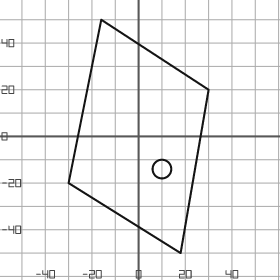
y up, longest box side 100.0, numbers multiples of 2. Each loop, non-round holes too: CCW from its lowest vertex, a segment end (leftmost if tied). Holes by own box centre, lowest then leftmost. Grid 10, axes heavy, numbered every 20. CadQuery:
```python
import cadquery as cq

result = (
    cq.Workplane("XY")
    .moveTo(18.0, -50.0)
    .lineTo(30.0, 20.0)
    .lineTo(-16.0, 50.0)
    .lineTo(-30.0, -20.0)
    .close()
    .moveTo(10.0, -14.0)
    .circle(4.0)
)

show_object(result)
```